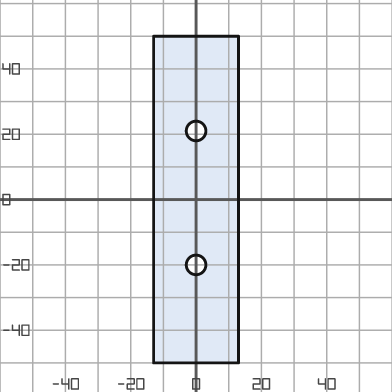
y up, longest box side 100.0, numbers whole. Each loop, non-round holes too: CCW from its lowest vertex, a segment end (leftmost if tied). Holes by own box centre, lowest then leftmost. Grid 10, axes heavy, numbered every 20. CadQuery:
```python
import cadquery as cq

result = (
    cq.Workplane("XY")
    .moveTo(-13.0, -50.0)
    .lineTo(13.0, -50.0)
    .lineTo(13.0, 50.0)
    .lineTo(-13.0, 50.0)
    .close()
    .moveTo(0.0, -20.0)
    .circle(3.0)
    .moveTo(0.0, 21.0)
    .circle(3.0)
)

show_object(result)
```